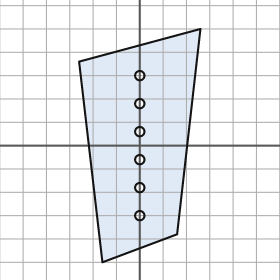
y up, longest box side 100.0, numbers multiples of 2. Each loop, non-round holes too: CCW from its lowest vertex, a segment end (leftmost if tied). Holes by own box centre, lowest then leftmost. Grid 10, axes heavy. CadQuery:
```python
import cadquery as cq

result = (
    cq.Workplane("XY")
    .moveTo(-16.0, -50.0)
    .lineTo(16.0, -38.0)
    .lineTo(26.0, 50.0)
    .lineTo(-26.0, 36.0)
    .close()
    .moveTo(0.0, -30.0)
    .circle(2.0)
    .moveTo(0.0, -18.0)
    .circle(2.0)
    .moveTo(0.0, -6.0)
    .circle(2.0)
    .moveTo(0.0, 6.0)
    .circle(2.0)
    .moveTo(0.0, 18.0)
    .circle(2.0)
    .moveTo(0.0, 30.0)
    .circle(2.0)
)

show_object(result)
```